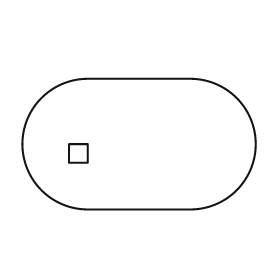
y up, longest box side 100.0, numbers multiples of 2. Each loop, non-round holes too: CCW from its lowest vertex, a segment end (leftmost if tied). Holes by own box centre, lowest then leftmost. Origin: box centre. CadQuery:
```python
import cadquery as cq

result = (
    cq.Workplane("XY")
    .moveTo(-22.0, -28.0)
    .lineTo(22.0, -28.0)
    .threePointArc((50.0, 0.0), (22.0, 28.0))
    .lineTo(-22.0, 28.0)
    .threePointArc((-50.0, 0.0), (-22.0, -28.0))
    .close()
    .moveTo(-30.0, -8.0)
    .lineTo(-22.0, -8.0)
    .lineTo(-22.0, 0.0)
    .lineTo(-30.0, 0.0)
    .close()
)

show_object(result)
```